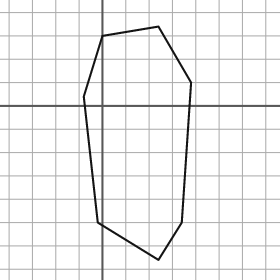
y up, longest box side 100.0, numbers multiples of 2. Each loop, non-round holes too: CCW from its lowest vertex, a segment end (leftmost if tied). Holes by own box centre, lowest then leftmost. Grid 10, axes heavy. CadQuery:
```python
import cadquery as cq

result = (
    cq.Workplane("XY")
    .moveTo(24.0, -66.0)
    .lineTo(34.0, -50.0)
    .lineTo(38.0, 10.0)
    .lineTo(24.0, 34.0)
    .lineTo(0.0, 30.0)
    .lineTo(-8.0, 4.0)
    .lineTo(-2.0, -50.0)
    .close()
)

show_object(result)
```